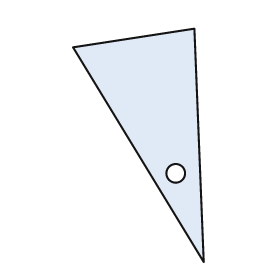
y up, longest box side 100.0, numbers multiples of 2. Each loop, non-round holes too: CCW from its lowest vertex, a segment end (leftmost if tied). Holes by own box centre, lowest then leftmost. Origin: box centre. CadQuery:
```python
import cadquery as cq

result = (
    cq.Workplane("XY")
    .moveTo(28.0, -50.0)
    .lineTo(24.0, 50.0)
    .lineTo(-28.0, 42.0)
    .close()
    .moveTo(16.0, -12.0)
    .circle(4.0)
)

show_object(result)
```